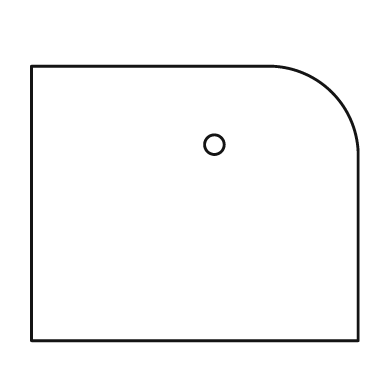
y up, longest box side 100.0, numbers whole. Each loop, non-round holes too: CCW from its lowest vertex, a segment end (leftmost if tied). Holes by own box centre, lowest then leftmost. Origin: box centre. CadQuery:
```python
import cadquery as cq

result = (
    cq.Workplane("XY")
    .moveTo(-50.0, -42.0)
    .lineTo(50.0, -42.0)
    .lineTo(50.0, 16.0)
    .threePointArc((42.0, 34.0), (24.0, 42.0))
    .lineTo(-50.0, 42.0)
    .close()
    .moveTo(6.0, 18.0)
    .circle(3.0)
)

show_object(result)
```